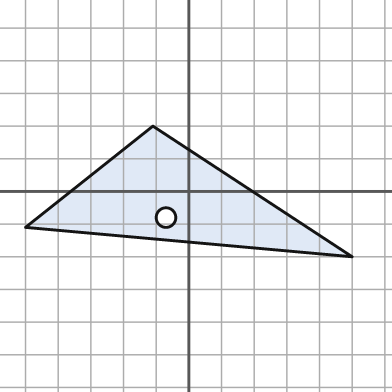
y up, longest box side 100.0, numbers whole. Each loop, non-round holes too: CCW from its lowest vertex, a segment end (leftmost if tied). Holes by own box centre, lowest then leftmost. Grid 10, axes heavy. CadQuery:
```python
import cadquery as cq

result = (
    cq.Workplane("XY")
    .moveTo(50.0, -20.0)
    .lineTo(-11.0, 20.0)
    .lineTo(-50.0, -11.0)
    .close()
    .moveTo(-7.0, -8.0)
    .circle(3.0)
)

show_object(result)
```